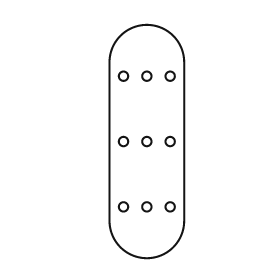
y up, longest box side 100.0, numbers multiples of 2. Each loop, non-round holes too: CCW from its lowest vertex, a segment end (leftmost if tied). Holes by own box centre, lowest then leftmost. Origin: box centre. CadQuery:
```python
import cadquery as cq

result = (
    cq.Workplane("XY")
    .moveTo(-16.0, -34.0)
    .threePointArc((0.0, -50.0), (16.0, -34.0))
    .lineTo(16.0, 34.0)
    .threePointArc((0.0, 50.0), (-16.0, 34.0))
    .close()
    .moveTo(-10.0, -28.0)
    .circle(2.0)
    .moveTo(0.0, -28.0)
    .circle(2.0)
    .moveTo(10.0, -28.0)
    .circle(2.0)
    .moveTo(-10.0, 0.0)
    .circle(2.0)
    .moveTo(0.0, 0.0)
    .circle(2.0)
    .moveTo(10.0, 0.0)
    .circle(2.0)
    .moveTo(-10.0, 28.0)
    .circle(2.0)
    .moveTo(0.0, 28.0)
    .circle(2.0)
    .moveTo(10.0, 28.0)
    .circle(2.0)
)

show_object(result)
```